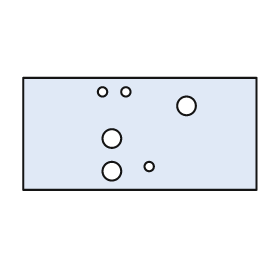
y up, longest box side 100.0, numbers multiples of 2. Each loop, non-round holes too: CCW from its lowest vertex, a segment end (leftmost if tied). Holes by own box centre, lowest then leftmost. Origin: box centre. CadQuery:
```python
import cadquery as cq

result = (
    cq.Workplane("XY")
    .moveTo(-50.0, -24.0)
    .lineTo(50.0, -24.0)
    .lineTo(50.0, 24.0)
    .lineTo(-50.0, 24.0)
    .close()
    .moveTo(-12.0, -16.0)
    .circle(4.0)
    .moveTo(4.0, -14.0)
    .circle(2.0)
    .moveTo(-12.0, -2.0)
    .circle(4.0)
    .moveTo(20.0, 12.0)
    .circle(4.0)
    .moveTo(-16.0, 18.0)
    .circle(2.0)
    .moveTo(-6.0, 18.0)
    .circle(2.0)
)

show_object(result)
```